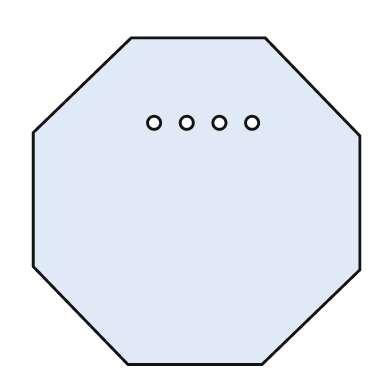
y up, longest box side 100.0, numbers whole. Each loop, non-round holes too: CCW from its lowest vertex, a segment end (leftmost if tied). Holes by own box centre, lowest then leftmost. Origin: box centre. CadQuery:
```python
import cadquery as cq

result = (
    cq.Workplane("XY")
    .moveTo(-21.0, -50.0)
    .lineTo(20.0, -50.0)
    .lineTo(50.0, -21.0)
    .lineTo(50.0, 20.0)
    .lineTo(21.0, 50.0)
    .lineTo(-20.0, 50.0)
    .lineTo(-50.0, 21.0)
    .lineTo(-50.0, -20.0)
    .close()
    .moveTo(-13.0, 24.0)
    .circle(2.0)
    .moveTo(-3.0, 24.0)
    .circle(2.0)
    .moveTo(7.0, 24.0)
    .circle(2.0)
    .moveTo(17.0, 24.0)
    .circle(2.0)
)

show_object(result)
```